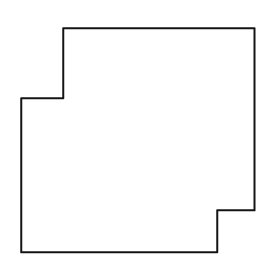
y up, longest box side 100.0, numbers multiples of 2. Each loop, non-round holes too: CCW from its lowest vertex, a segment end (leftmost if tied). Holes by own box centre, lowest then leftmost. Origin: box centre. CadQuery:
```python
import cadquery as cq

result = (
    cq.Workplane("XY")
    .moveTo(-50.0, -48.0)
    .lineTo(34.0, -48.0)
    .lineTo(34.0, -30.0)
    .lineTo(50.0, -30.0)
    .lineTo(50.0, 48.0)
    .lineTo(-32.0, 48.0)
    .lineTo(-32.0, 18.0)
    .lineTo(-50.0, 18.0)
    .close()
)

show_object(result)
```